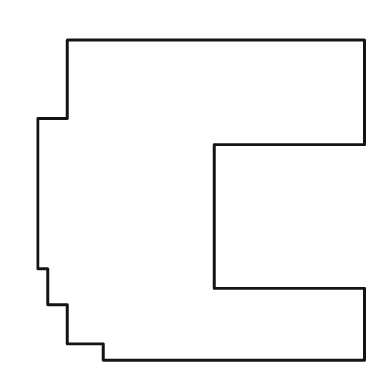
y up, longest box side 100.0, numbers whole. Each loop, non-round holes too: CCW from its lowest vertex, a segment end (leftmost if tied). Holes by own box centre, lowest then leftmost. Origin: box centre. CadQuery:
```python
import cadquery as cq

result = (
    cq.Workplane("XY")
    .moveTo(-30.0, -49.0)
    .lineTo(50.0, -49.0)
    .lineTo(50.0, -27.0)
    .lineTo(4.0, -27.0)
    .lineTo(4.0, 17.0)
    .lineTo(50.0, 17.0)
    .lineTo(50.0, 49.0)
    .lineTo(-41.0, 49.0)
    .lineTo(-41.0, 25.0)
    .lineTo(-50.0, 25.0)
    .lineTo(-50.0, -21.0)
    .lineTo(-47.0, -21.0)
    .lineTo(-47.0, -32.0)
    .lineTo(-41.0, -32.0)
    .lineTo(-41.0, -44.0)
    .lineTo(-30.0, -44.0)
    .close()
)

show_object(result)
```